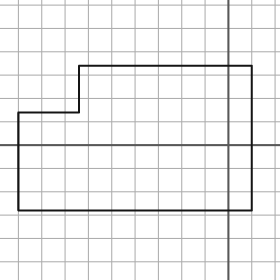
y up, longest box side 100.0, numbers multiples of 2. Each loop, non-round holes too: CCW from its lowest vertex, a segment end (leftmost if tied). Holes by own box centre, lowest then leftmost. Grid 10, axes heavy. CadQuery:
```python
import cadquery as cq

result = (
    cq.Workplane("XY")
    .moveTo(-90.0, -28.0)
    .lineTo(10.0, -28.0)
    .lineTo(10.0, 34.0)
    .lineTo(-64.0, 34.0)
    .lineTo(-64.0, 14.0)
    .lineTo(-90.0, 14.0)
    .close()
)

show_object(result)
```